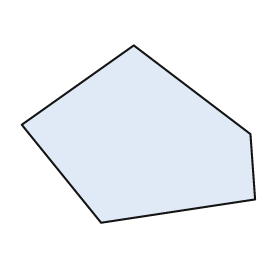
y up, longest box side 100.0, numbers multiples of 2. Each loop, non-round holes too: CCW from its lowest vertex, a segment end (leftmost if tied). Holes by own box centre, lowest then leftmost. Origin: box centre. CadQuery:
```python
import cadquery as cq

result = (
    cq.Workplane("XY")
    .moveTo(-16.0, -38.0)
    .lineTo(50.0, -28.0)
    .lineTo(48.0, 0.0)
    .lineTo(-2.0, 38.0)
    .lineTo(-50.0, 4.0)
    .close()
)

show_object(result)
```